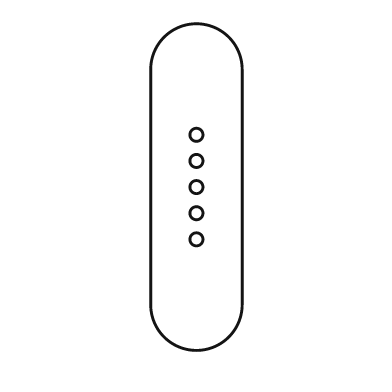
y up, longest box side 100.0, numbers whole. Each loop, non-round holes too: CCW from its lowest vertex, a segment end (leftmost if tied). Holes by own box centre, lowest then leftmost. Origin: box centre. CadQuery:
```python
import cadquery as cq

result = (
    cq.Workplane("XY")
    .moveTo(-14.0, -36.0)
    .threePointArc((0.0, -50.0), (14.0, -36.0))
    .lineTo(14.0, 36.0)
    .threePointArc((0.0, 50.0), (-14.0, 36.0))
    .close()
    .moveTo(0.0, -16.0)
    .circle(2.0)
    .moveTo(0.0, -8.0)
    .circle(2.0)
    .moveTo(0.0, 0.0)
    .circle(2.0)
    .moveTo(0.0, 8.0)
    .circle(2.0)
    .moveTo(0.0, 16.0)
    .circle(2.0)
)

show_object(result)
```